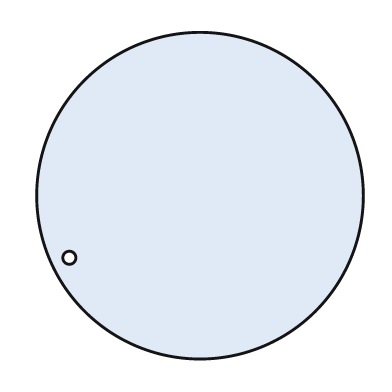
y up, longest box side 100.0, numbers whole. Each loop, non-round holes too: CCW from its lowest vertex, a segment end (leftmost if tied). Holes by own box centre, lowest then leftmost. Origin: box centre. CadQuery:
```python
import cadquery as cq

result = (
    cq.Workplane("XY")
    .moveTo(0.0, 0.0)
    .circle(50.0)
    .moveTo(-40.0, -19.0)
    .circle(2.0)
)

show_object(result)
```